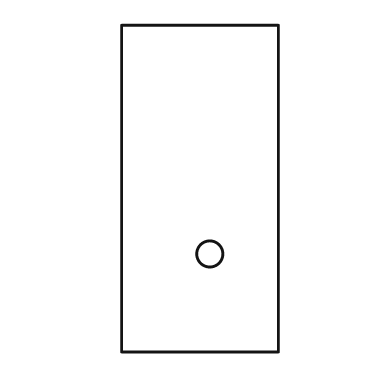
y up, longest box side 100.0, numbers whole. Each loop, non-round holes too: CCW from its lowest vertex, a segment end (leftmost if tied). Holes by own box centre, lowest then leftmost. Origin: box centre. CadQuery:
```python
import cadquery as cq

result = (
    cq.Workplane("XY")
    .moveTo(-24.0, -50.0)
    .lineTo(24.0, -50.0)
    .lineTo(24.0, 50.0)
    .lineTo(-24.0, 50.0)
    .close()
    .moveTo(3.0, -20.0)
    .circle(4.0)
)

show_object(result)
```